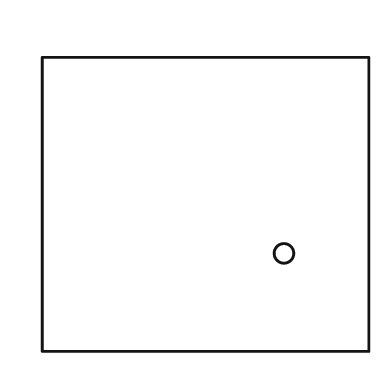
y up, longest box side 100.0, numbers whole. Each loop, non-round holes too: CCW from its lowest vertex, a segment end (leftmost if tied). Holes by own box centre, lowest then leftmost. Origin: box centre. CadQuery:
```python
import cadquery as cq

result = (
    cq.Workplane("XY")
    .moveTo(-50.0, -45.0)
    .lineTo(50.0, -45.0)
    .lineTo(50.0, 45.0)
    .lineTo(-50.0, 45.0)
    .close()
    .moveTo(24.0, -15.0)
    .circle(3.0)
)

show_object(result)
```